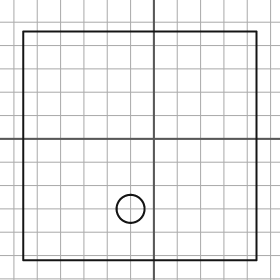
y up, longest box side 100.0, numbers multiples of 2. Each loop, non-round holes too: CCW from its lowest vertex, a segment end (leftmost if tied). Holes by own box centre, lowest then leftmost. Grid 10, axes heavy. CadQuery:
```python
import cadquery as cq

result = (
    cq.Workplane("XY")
    .moveTo(-56.0, -52.0)
    .lineTo(44.0, -52.0)
    .lineTo(44.0, 46.0)
    .lineTo(-56.0, 46.0)
    .close()
    .moveTo(-10.0, -30.0)
    .circle(6.0)
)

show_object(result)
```